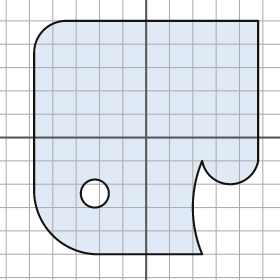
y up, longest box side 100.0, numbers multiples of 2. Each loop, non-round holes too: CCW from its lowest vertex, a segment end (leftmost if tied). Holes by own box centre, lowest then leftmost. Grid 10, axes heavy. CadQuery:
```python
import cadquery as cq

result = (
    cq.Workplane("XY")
    .moveTo(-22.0, -50.0)
    .lineTo(24.0, -50.0)
    .threePointArc((20.0, -30.0), (24.0, -10.0))
    .threePointArc((36.0, -20.0), (48.0, -10.0))
    .lineTo(48.0, 50.0)
    .lineTo(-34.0, 50.0)
    .threePointArc((-44.0, 46.0), (-48.0, 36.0))
    .lineTo(-48.0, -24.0)
    .threePointArc((-40.0, -42.0), (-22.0, -50.0))
    .close()
    .moveTo(-22.0, -24.0)
    .circle(6.0)
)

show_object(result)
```